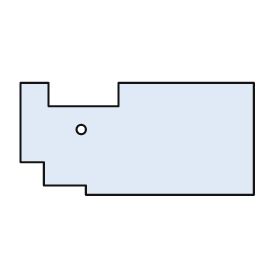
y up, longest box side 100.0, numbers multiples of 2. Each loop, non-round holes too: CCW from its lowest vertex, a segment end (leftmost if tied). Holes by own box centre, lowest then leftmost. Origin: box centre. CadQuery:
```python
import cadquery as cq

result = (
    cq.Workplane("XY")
    .moveTo(-22.0, -24.0)
    .lineTo(50.0, -24.0)
    .lineTo(50.0, 24.0)
    .lineTo(-8.0, 24.0)
    .lineTo(-8.0, 14.0)
    .lineTo(-38.0, 14.0)
    .lineTo(-38.0, 24.0)
    .lineTo(-50.0, 24.0)
    .lineTo(-50.0, -10.0)
    .lineTo(-40.0, -10.0)
    .lineTo(-40.0, -20.0)
    .lineTo(-22.0, -20.0)
    .close()
    .moveTo(-24.0, 4.0)
    .circle(2.0)
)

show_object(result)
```